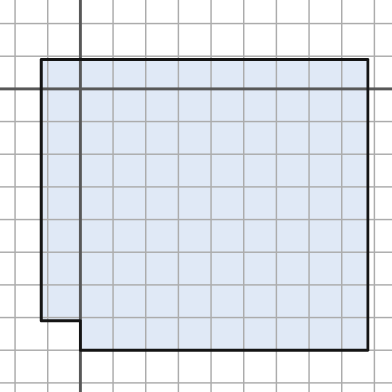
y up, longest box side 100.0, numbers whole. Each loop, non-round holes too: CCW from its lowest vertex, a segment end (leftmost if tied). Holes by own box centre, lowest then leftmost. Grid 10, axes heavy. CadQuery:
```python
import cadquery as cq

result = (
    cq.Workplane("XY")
    .moveTo(0.0, -80.0)
    .lineTo(88.0, -80.0)
    .lineTo(88.0, 9.0)
    .lineTo(-12.0, 9.0)
    .lineTo(-12.0, -71.0)
    .lineTo(0.0, -71.0)
    .close()
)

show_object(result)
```